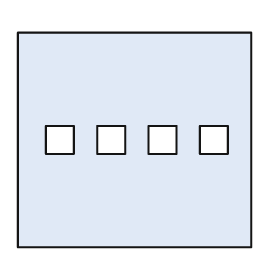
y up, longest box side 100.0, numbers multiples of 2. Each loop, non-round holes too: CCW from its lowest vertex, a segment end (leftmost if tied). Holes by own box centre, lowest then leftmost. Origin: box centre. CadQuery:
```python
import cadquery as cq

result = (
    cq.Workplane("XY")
    .moveTo(-50.0, -46.0)
    .lineTo(50.0, -46.0)
    .lineTo(50.0, 46.0)
    .lineTo(-50.0, 46.0)
    .close()
    .moveTo(-38.0, -6.0)
    .lineTo(-26.0, -6.0)
    .lineTo(-26.0, 6.0)
    .lineTo(-38.0, 6.0)
    .close()
    .moveTo(-16.0, -6.0)
    .lineTo(-4.0, -6.0)
    .lineTo(-4.0, 6.0)
    .lineTo(-16.0, 6.0)
    .close()
    .moveTo(6.0, -6.0)
    .lineTo(18.0, -6.0)
    .lineTo(18.0, 6.0)
    .lineTo(6.0, 6.0)
    .close()
    .moveTo(28.0, -6.0)
    .lineTo(40.0, -6.0)
    .lineTo(40.0, 6.0)
    .lineTo(28.0, 6.0)
    .close()
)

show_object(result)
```